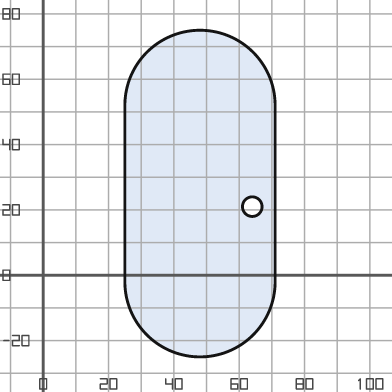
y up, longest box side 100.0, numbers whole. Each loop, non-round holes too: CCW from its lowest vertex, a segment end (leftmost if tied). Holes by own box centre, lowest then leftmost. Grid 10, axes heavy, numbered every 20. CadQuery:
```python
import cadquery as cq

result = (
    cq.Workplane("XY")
    .moveTo(25.0, -2.0)
    .threePointArc((48.0, -25.0), (71.0, -2.0))
    .lineTo(71.0, 52.0)
    .threePointArc((48.0, 75.0), (25.0, 52.0))
    .close()
    .moveTo(64.0, 21.0)
    .circle(3.0)
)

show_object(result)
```